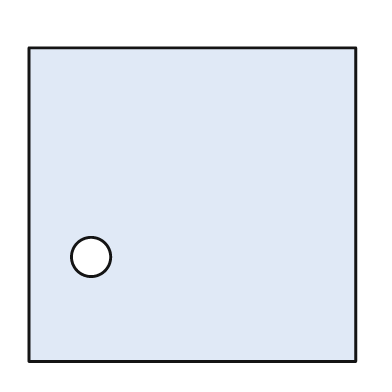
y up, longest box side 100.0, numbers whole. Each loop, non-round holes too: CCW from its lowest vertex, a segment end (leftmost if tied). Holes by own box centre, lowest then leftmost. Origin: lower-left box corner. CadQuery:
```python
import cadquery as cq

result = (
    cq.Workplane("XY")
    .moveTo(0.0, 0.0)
    .lineTo(100.0, 0.0)
    .lineTo(100.0, 96.0)
    .lineTo(0.0, 96.0)
    .close()
    .moveTo(19.0, 32.0)
    .circle(6.0)
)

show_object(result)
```